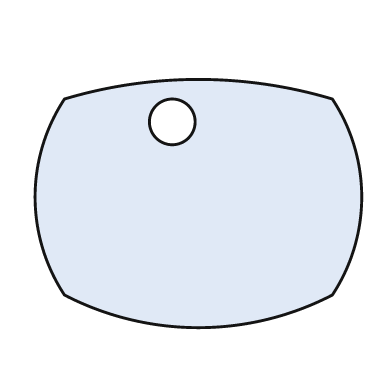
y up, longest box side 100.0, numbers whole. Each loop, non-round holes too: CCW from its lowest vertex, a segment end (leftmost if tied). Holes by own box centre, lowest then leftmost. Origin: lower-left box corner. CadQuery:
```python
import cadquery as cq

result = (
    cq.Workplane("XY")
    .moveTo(9.0, 10.0)
    .threePointArc((50.0, 0.0), (91.0, 10.0))
    .threePointArc((100.0, 40.0), (91.0, 70.0))
    .threePointArc((50.0, 76.0), (9.0, 70.0))
    .threePointArc((0.0, 40.0), (9.0, 10.0))
    .close()
    .moveTo(42.0, 63.0)
    .circle(7.0)
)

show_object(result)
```